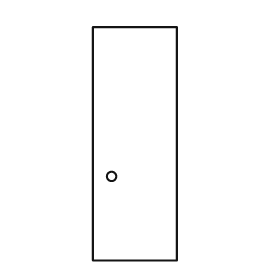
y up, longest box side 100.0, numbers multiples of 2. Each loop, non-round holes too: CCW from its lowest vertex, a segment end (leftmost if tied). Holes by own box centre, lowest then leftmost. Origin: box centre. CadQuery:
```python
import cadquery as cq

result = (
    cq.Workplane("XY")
    .moveTo(-18.0, -50.0)
    .lineTo(18.0, -50.0)
    .lineTo(18.0, 50.0)
    .lineTo(-18.0, 50.0)
    .close()
    .moveTo(-10.0, -14.0)
    .circle(2.0)
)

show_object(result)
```